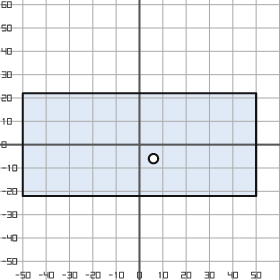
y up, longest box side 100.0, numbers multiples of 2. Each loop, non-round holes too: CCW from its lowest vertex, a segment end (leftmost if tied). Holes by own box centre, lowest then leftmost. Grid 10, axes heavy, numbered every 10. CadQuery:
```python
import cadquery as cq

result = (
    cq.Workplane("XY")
    .moveTo(-50.0, -22.0)
    .lineTo(50.0, -22.0)
    .lineTo(50.0, 22.0)
    .lineTo(-50.0, 22.0)
    .close()
    .moveTo(6.0, -6.0)
    .circle(2.0)
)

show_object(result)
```